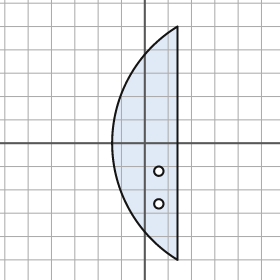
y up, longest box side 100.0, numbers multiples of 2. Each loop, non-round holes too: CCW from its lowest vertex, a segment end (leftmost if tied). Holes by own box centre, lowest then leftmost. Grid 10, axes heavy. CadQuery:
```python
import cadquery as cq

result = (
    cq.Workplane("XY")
    .moveTo(14.0, -50.0)
    .lineTo(14.0, 50.0)
    .threePointArc((-14.0, 0.0), (14.0, -50.0))
    .close()
    .moveTo(6.0, -26.0)
    .circle(2.0)
    .moveTo(6.0, -12.0)
    .circle(2.0)
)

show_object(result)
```